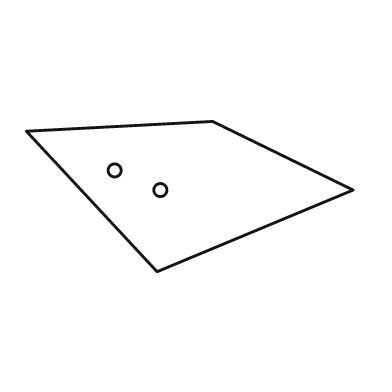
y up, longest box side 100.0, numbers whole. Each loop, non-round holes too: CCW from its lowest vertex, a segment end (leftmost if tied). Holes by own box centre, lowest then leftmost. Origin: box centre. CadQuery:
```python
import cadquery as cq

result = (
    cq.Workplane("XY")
    .moveTo(-10.0, -23.0)
    .lineTo(50.0, 2.0)
    .lineTo(7.0, 23.0)
    .lineTo(-50.0, 20.0)
    .close()
    .moveTo(-9.0, 2.0)
    .circle(2.0)
    .moveTo(-23.0, 8.0)
    .circle(2.0)
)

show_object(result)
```